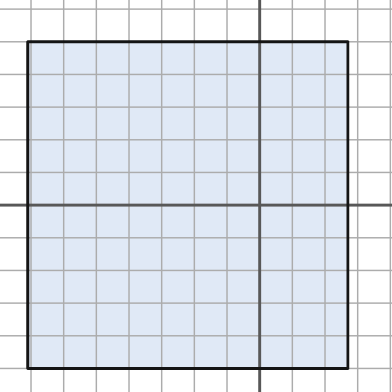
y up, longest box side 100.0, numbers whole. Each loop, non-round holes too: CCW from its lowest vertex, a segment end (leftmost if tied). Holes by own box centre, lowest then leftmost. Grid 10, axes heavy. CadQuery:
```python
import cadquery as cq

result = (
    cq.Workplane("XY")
    .moveTo(-71.0, -50.0)
    .lineTo(27.0, -50.0)
    .lineTo(27.0, 50.0)
    .lineTo(-71.0, 50.0)
    .close()
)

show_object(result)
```